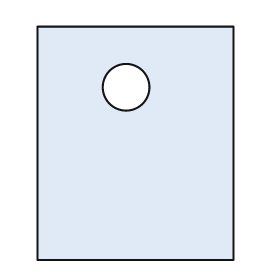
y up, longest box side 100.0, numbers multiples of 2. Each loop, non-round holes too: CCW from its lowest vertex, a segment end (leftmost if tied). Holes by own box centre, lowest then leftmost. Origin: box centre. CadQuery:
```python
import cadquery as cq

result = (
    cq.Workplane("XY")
    .moveTo(-42.0, -50.0)
    .lineTo(42.0, -50.0)
    .lineTo(42.0, 50.0)
    .lineTo(-42.0, 50.0)
    .close()
    .moveTo(-4.0, 24.0)
    .circle(10.0)
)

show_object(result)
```